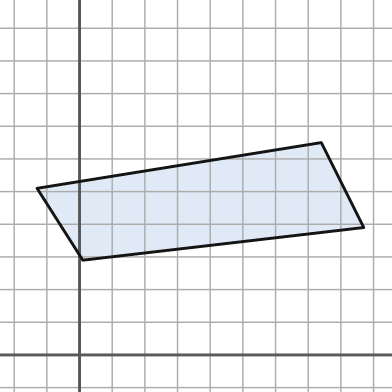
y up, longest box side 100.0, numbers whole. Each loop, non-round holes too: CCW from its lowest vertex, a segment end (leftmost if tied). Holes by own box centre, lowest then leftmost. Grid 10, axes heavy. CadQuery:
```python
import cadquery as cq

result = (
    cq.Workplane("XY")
    .moveTo(1.0, 29.0)
    .lineTo(87.0, 39.0)
    .lineTo(74.0, 65.0)
    .lineTo(-13.0, 51.0)
    .close()
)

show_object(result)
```